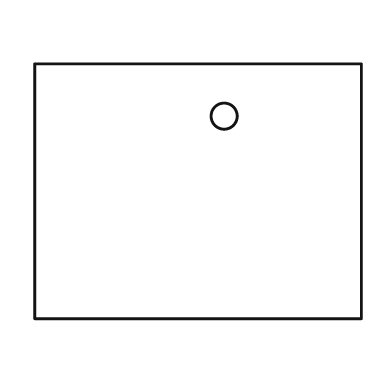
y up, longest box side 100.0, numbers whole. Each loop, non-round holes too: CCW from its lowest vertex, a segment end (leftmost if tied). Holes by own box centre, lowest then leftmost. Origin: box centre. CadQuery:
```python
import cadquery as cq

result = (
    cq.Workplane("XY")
    .moveTo(-50.0, -39.0)
    .lineTo(50.0, -39.0)
    .lineTo(50.0, 39.0)
    .lineTo(-50.0, 39.0)
    .close()
    .moveTo(8.0, 23.0)
    .circle(4.0)
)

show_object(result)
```